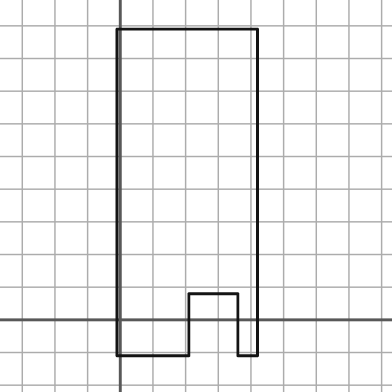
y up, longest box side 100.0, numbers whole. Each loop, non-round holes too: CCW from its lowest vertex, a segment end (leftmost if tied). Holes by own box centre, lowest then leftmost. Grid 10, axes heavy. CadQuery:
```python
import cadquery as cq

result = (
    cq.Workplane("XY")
    .moveTo(-1.0, -11.0)
    .lineTo(21.0, -11.0)
    .lineTo(21.0, 8.0)
    .lineTo(36.0, 8.0)
    .lineTo(36.0, -11.0)
    .lineTo(42.0, -11.0)
    .lineTo(42.0, 89.0)
    .lineTo(-1.0, 89.0)
    .close()
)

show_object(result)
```